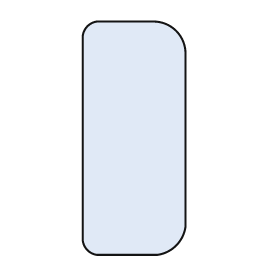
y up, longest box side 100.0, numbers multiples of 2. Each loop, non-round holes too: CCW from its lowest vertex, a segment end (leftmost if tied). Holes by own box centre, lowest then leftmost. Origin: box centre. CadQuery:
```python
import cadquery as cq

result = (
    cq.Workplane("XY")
    .moveTo(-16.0, -50.0)
    .lineTo(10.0, -50.0)
    .threePointArc((18.0, -46.0), (22.0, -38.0))
    .lineTo(22.0, 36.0)
    .threePointArc((18.0, 46.0), (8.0, 50.0))
    .lineTo(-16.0, 50.0)
    .threePointArc((-20.0, 48.0), (-22.0, 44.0))
    .lineTo(-22.0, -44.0)
    .threePointArc((-20.0, -48.0), (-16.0, -50.0))
    .close()
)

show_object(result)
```